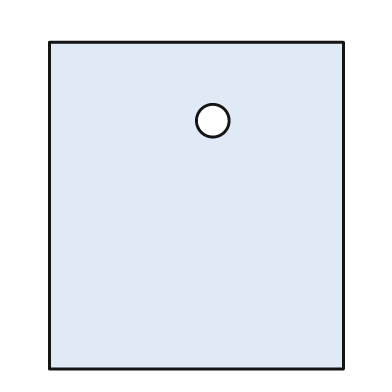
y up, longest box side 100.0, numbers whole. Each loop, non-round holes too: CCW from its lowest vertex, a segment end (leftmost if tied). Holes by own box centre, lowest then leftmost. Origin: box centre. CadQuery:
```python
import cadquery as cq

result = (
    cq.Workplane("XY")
    .moveTo(-45.0, -50.0)
    .lineTo(45.0, -50.0)
    .lineTo(45.0, 50.0)
    .lineTo(-45.0, 50.0)
    .close()
    .moveTo(5.0, 26.0)
    .circle(5.0)
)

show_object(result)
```